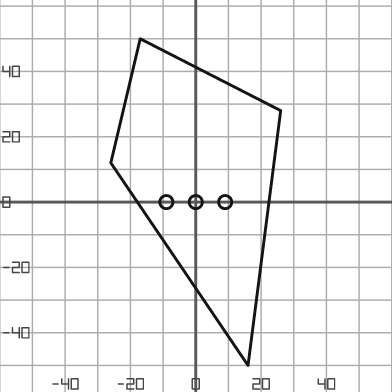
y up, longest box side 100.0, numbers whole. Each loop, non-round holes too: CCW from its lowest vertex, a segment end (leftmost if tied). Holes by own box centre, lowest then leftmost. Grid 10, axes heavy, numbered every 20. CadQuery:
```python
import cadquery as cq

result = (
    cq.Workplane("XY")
    .moveTo(16.0, -50.0)
    .lineTo(26.0, 28.0)
    .lineTo(-17.0, 50.0)
    .lineTo(-26.0, 12.0)
    .close()
    .moveTo(-9.0, 0.0)
    .circle(2.0)
    .moveTo(0.0, 0.0)
    .circle(2.0)
    .moveTo(9.0, 0.0)
    .circle(2.0)
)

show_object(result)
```